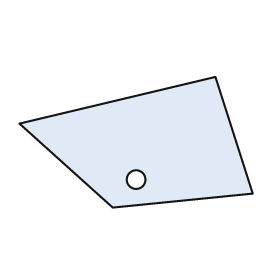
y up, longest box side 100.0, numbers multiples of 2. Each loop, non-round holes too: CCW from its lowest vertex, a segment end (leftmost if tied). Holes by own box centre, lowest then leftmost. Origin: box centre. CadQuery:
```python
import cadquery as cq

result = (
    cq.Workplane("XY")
    .moveTo(-10.0, -28.0)
    .lineTo(50.0, -22.0)
    .lineTo(34.0, 28.0)
    .lineTo(-50.0, 8.0)
    .close()
    .moveTo(0.0, -16.0)
    .circle(4.0)
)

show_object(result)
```